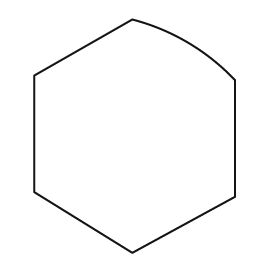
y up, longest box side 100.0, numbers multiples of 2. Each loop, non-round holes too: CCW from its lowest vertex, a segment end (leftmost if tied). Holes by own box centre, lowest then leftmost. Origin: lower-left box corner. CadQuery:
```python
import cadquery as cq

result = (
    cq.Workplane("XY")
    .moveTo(42.0, 0.0)
    .lineTo(86.0, 24.0)
    .lineTo(86.0, 74.0)
    .threePointArc((66.0, 90.0), (42.0, 100.0))
    .lineTo(0.0, 76.0)
    .lineTo(0.0, 26.0)
    .close()
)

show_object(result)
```